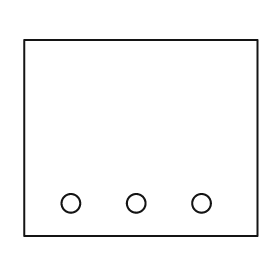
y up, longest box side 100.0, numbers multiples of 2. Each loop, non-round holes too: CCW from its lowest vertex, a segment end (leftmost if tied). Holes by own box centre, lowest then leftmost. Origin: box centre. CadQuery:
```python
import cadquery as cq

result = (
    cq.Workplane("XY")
    .moveTo(-50.0, -42.0)
    .lineTo(50.0, -42.0)
    .lineTo(50.0, 42.0)
    .lineTo(-50.0, 42.0)
    .close()
    .moveTo(-30.0, -28.0)
    .circle(4.0)
    .moveTo(-2.0, -28.0)
    .circle(4.0)
    .moveTo(26.0, -28.0)
    .circle(4.0)
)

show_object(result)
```